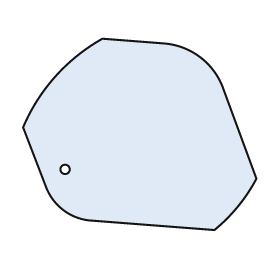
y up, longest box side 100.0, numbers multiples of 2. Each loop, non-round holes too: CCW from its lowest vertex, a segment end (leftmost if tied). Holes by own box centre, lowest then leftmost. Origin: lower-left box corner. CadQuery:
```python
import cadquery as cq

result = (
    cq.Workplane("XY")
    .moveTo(82.0, 0.0)
    .threePointArc((92.0, 10.0), (100.0, 22.0))
    .lineTo(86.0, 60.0)
    .threePointArc((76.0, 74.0), (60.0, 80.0))
    .lineTo(34.0, 82.0)
    .threePointArc((14.0, 66.0), (0.0, 44.0))
    .lineTo(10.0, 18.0)
    .threePointArc((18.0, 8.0), (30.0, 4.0))
    .close()
    .moveTo(18.0, 26.0)
    .circle(2.0)
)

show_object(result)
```